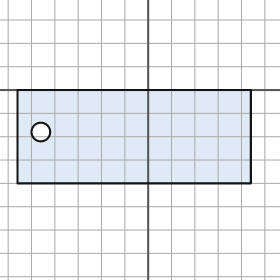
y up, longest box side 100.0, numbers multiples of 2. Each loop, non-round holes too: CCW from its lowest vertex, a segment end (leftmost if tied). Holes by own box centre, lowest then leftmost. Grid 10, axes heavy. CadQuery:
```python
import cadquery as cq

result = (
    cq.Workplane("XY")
    .moveTo(-56.0, -40.0)
    .lineTo(44.0, -40.0)
    .lineTo(44.0, 0.0)
    .lineTo(-56.0, 0.0)
    .close()
    .moveTo(-46.0, -18.0)
    .circle(4.0)
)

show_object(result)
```